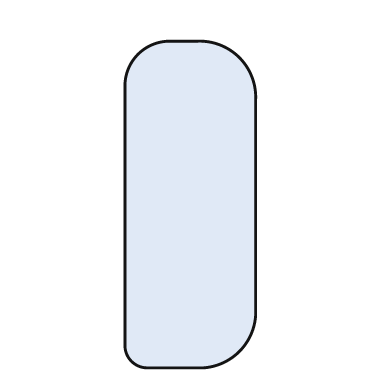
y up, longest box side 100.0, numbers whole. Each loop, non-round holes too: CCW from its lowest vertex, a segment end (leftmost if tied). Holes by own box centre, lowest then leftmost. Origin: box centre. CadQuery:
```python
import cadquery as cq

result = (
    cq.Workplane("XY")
    .moveTo(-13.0, -50.0)
    .lineTo(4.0, -50.0)
    .threePointArc((15.0, -45.0), (20.0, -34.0))
    .lineTo(20.0, 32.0)
    .threePointArc((15.0, 45.0), (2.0, 50.0))
    .lineTo(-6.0, 50.0)
    .threePointArc((-16.0, 46.0), (-20.0, 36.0))
    .lineTo(-20.0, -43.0)
    .threePointArc((-18.0, -48.0), (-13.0, -50.0))
    .close()
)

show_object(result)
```